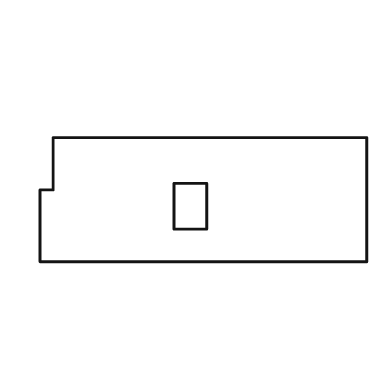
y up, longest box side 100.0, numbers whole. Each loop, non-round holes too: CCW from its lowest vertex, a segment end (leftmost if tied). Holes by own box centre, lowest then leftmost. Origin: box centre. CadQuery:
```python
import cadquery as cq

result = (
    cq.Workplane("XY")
    .moveTo(-50.0, -19.0)
    .lineTo(50.0, -19.0)
    .lineTo(50.0, 19.0)
    .lineTo(-46.0, 19.0)
    .lineTo(-46.0, 3.0)
    .lineTo(-50.0, 3.0)
    .close()
    .moveTo(-9.0, -9.0)
    .lineTo(1.0, -9.0)
    .lineTo(1.0, 5.0)
    .lineTo(-9.0, 5.0)
    .close()
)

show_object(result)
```